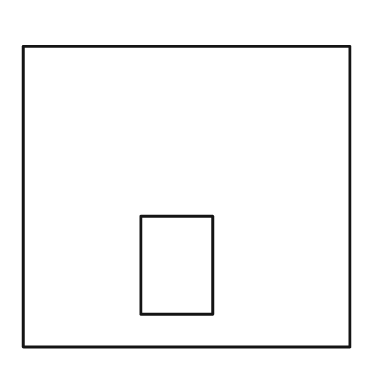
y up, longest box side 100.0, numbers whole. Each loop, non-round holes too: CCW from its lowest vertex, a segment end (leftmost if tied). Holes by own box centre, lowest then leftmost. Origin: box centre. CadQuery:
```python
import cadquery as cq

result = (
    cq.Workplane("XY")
    .moveTo(-50.0, -46.0)
    .lineTo(50.0, -46.0)
    .lineTo(50.0, 46.0)
    .lineTo(-50.0, 46.0)
    .close()
    .moveTo(-14.0, -36.0)
    .lineTo(8.0, -36.0)
    .lineTo(8.0, -6.0)
    .lineTo(-14.0, -6.0)
    .close()
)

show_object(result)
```